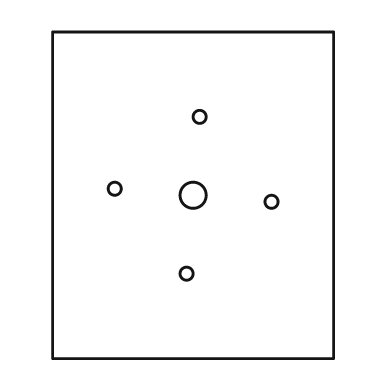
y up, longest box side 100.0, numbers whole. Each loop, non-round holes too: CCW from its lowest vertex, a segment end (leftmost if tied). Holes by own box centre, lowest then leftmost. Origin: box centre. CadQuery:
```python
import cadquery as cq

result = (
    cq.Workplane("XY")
    .moveTo(-43.0, -50.0)
    .lineTo(43.0, -50.0)
    .lineTo(43.0, 50.0)
    .lineTo(-43.0, 50.0)
    .close()
    .moveTo(-2.0, -24.0)
    .circle(2.0)
    .moveTo(24.0, -2.0)
    .circle(2.0)
    .moveTo(0.0, 0.0)
    .circle(4.0)
    .moveTo(-24.0, 2.0)
    .circle(2.0)
    .moveTo(2.0, 24.0)
    .circle(2.0)
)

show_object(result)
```